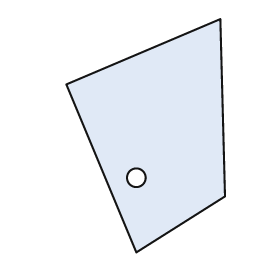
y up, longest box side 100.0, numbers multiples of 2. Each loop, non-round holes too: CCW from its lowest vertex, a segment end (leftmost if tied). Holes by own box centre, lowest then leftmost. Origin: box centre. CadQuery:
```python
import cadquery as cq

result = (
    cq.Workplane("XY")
    .moveTo(-4.0, -50.0)
    .lineTo(34.0, -26.0)
    .lineTo(32.0, 50.0)
    .lineTo(-34.0, 22.0)
    .close()
    .moveTo(-4.0, -18.0)
    .circle(4.0)
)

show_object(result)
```